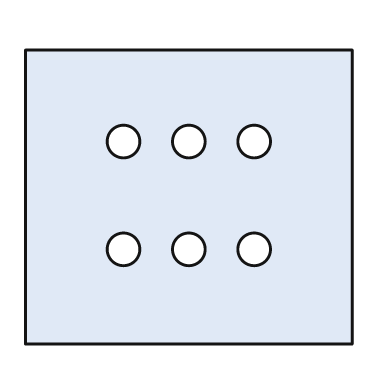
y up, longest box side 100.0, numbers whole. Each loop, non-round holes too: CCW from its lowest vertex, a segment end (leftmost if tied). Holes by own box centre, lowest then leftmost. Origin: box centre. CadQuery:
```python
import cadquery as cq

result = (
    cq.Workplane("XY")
    .moveTo(-50.0, -45.0)
    .lineTo(50.0, -45.0)
    .lineTo(50.0, 45.0)
    .lineTo(-50.0, 45.0)
    .close()
    .moveTo(-20.0, -16.0)
    .circle(5.0)
    .moveTo(0.0, -16.0)
    .circle(5.0)
    .moveTo(20.0, -16.0)
    .circle(5.0)
    .moveTo(-20.0, 17.0)
    .circle(5.0)
    .moveTo(0.0, 17.0)
    .circle(5.0)
    .moveTo(20.0, 17.0)
    .circle(5.0)
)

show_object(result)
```